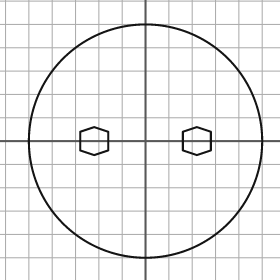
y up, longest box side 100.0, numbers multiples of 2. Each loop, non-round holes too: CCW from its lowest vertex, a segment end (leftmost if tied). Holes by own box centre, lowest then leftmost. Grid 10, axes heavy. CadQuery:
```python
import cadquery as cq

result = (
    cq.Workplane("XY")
    .moveTo(0.0, 0.0)
    .circle(50.0)
    .moveTo(-22.0, -6.0)
    .lineTo(-16.0, -4.0)
    .lineTo(-16.0, 4.0)
    .lineTo(-22.0, 6.0)
    .lineTo(-28.0, 4.0)
    .lineTo(-28.0, -4.0)
    .close()
    .moveTo(22.0, -6.0)
    .lineTo(28.0, -4.0)
    .lineTo(28.0, 4.0)
    .lineTo(22.0, 6.0)
    .lineTo(16.0, 4.0)
    .lineTo(16.0, -4.0)
    .close()
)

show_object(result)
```